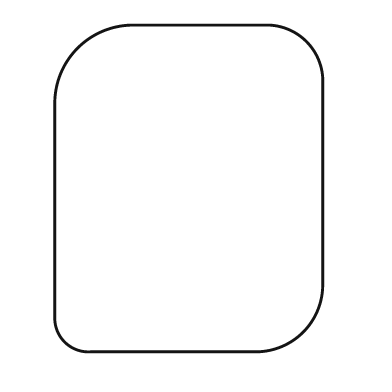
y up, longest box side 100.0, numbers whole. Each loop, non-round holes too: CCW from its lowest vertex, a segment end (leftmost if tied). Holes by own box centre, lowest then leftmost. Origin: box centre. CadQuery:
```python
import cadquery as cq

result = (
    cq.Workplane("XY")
    .moveTo(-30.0, -50.0)
    .lineTo(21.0, -50.0)
    .threePointArc((35.0, -44.0), (41.0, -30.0))
    .lineTo(41.0, 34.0)
    .threePointArc((36.0, 45.0), (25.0, 50.0))
    .lineTo(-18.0, 50.0)
    .threePointArc((-34.0, 43.0), (-41.0, 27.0))
    .lineTo(-41.0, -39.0)
    .threePointArc((-38.0, -47.0), (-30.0, -50.0))
    .close()
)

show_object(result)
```